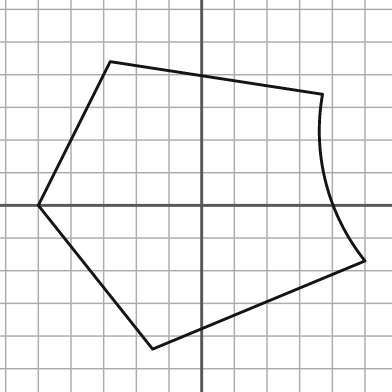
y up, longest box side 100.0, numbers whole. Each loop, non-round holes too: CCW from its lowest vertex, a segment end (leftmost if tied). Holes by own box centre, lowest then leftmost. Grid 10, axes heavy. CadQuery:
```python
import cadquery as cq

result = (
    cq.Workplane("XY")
    .moveTo(-15.0, -44.0)
    .lineTo(50.0, -17.0)
    .threePointArc((38.0, 7.0), (37.0, 34.0))
    .lineTo(-28.0, 44.0)
    .lineTo(-50.0, 0.0)
    .close()
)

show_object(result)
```